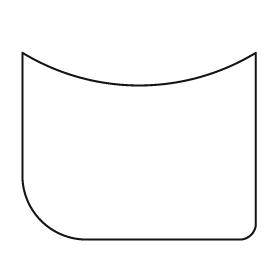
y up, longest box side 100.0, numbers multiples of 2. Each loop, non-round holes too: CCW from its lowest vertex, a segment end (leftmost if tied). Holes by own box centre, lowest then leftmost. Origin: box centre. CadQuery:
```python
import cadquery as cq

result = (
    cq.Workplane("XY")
    .moveTo(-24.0, -40.0)
    .lineTo(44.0, -40.0)
    .threePointArc((48.0, -38.0), (50.0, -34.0))
    .lineTo(50.0, 40.0)
    .threePointArc((0.0, 26.0), (-50.0, 40.0))
    .lineTo(-50.0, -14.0)
    .threePointArc((-42.0, -32.0), (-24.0, -40.0))
    .close()
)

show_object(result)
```